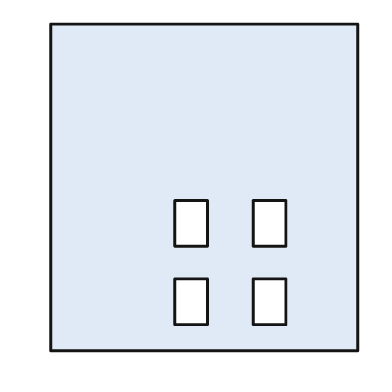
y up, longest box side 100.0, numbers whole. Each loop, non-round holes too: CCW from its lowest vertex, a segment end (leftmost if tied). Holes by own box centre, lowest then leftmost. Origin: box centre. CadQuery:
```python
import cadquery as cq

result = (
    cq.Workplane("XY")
    .moveTo(-47.0, -50.0)
    .lineTo(47.0, -50.0)
    .lineTo(47.0, 50.0)
    .lineTo(-47.0, 50.0)
    .close()
    .moveTo(-9.0, -42.0)
    .lineTo(1.0, -42.0)
    .lineTo(1.0, -28.0)
    .lineTo(-9.0, -28.0)
    .close()
    .moveTo(15.0, -42.0)
    .lineTo(25.0, -42.0)
    .lineTo(25.0, -28.0)
    .lineTo(15.0, -28.0)
    .close()
    .moveTo(-9.0, -18.0)
    .lineTo(1.0, -18.0)
    .lineTo(1.0, -4.0)
    .lineTo(-9.0, -4.0)
    .close()
    .moveTo(15.0, -18.0)
    .lineTo(25.0, -18.0)
    .lineTo(25.0, -4.0)
    .lineTo(15.0, -4.0)
    .close()
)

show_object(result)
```